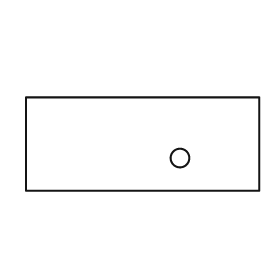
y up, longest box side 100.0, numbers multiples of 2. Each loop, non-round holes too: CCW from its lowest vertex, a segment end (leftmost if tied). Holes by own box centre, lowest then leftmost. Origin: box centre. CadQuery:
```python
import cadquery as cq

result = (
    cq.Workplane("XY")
    .moveTo(-50.0, -20.0)
    .lineTo(50.0, -20.0)
    .lineTo(50.0, 20.0)
    .lineTo(-50.0, 20.0)
    .close()
    .moveTo(16.0, -6.0)
    .circle(4.0)
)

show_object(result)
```